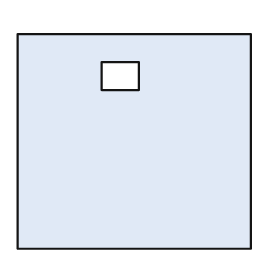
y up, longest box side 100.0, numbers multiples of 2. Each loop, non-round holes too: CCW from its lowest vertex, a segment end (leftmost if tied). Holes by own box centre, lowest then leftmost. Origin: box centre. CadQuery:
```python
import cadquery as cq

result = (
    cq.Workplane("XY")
    .moveTo(-50.0, -46.0)
    .lineTo(50.0, -46.0)
    .lineTo(50.0, 46.0)
    .lineTo(-50.0, 46.0)
    .close()
    .moveTo(-14.0, 22.0)
    .lineTo(2.0, 22.0)
    .lineTo(2.0, 34.0)
    .lineTo(-14.0, 34.0)
    .close()
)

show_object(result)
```